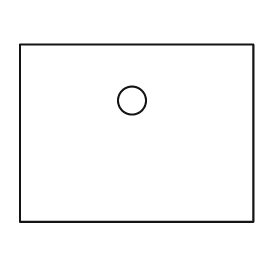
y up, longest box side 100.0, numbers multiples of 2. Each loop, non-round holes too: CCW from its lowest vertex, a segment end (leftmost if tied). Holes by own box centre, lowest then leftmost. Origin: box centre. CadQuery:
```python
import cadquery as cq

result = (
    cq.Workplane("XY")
    .moveTo(-50.0, -38.0)
    .lineTo(50.0, -38.0)
    .lineTo(50.0, 38.0)
    .lineTo(-50.0, 38.0)
    .close()
    .moveTo(-2.0, 14.0)
    .circle(6.0)
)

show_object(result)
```